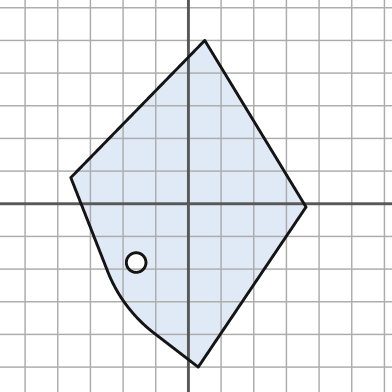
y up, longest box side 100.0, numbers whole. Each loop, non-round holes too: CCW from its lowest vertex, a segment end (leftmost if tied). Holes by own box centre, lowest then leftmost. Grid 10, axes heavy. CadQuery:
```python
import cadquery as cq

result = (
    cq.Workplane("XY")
    .moveTo(3.0, -50.0)
    .lineTo(36.0, -1.0)
    .lineTo(5.0, 50.0)
    .lineTo(-36.0, 8.0)
    .lineTo(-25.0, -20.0)
    .threePointArc((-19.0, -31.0), (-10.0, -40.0))
    .close()
    .moveTo(-16.0, -18.0)
    .circle(3.0)
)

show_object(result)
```